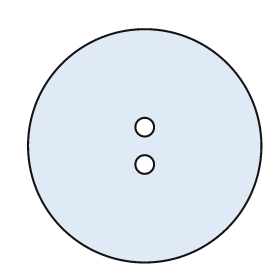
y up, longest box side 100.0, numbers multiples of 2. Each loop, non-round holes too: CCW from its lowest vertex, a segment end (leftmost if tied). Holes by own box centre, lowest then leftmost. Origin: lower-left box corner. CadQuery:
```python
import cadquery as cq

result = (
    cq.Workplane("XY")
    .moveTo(50.0, 50.0)
    .circle(50.0)
    .moveTo(50.0, 42.0)
    .circle(4.0)
    .moveTo(50.0, 58.0)
    .circle(4.0)
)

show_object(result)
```